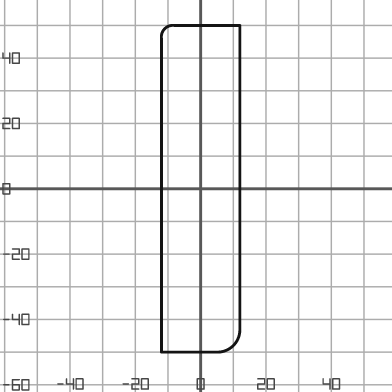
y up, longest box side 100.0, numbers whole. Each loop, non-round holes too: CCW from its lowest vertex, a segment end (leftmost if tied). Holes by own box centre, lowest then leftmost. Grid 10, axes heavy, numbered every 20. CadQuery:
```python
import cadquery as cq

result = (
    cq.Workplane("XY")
    .moveTo(-12.0, -50.0)
    .lineTo(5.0, -50.0)
    .threePointArc((10.0, -48.0), (12.0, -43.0))
    .lineTo(12.0, 50.0)
    .lineTo(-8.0, 50.0)
    .threePointArc((-11.0, 49.0), (-12.0, 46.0))
    .close()
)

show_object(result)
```